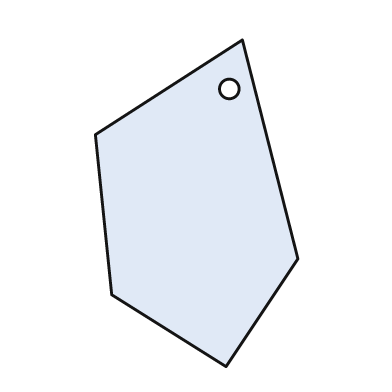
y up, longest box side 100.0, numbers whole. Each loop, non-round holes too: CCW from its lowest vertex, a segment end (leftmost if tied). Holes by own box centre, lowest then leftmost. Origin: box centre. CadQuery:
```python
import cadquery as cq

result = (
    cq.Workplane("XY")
    .moveTo(9.0, -50.0)
    .lineTo(31.0, -17.0)
    .lineTo(14.0, 50.0)
    .lineTo(-31.0, 21.0)
    .lineTo(-26.0, -28.0)
    .close()
    .moveTo(10.0, 35.0)
    .circle(3.0)
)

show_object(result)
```